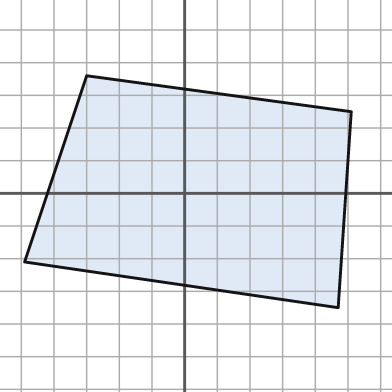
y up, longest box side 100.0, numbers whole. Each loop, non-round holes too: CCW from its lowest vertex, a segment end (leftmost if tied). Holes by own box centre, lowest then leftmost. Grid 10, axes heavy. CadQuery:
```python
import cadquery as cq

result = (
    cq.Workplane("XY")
    .moveTo(47.0, -35.0)
    .lineTo(51.0, 25.0)
    .lineTo(-30.0, 36.0)
    .lineTo(-49.0, -21.0)
    .close()
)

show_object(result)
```